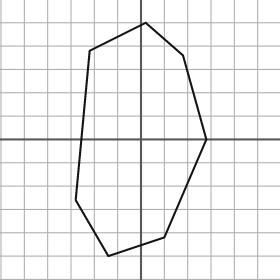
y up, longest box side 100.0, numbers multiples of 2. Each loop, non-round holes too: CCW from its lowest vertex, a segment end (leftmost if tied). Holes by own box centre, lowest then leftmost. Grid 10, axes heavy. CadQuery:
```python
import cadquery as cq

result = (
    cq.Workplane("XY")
    .moveTo(-14.0, -50.0)
    .lineTo(10.0, -42.0)
    .lineTo(28.0, 0.0)
    .lineTo(18.0, 36.0)
    .lineTo(2.0, 50.0)
    .lineTo(-22.0, 38.0)
    .lineTo(-28.0, -26.0)
    .close()
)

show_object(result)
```